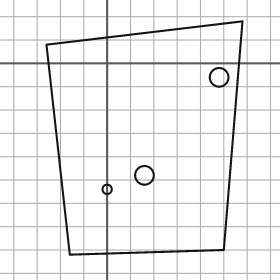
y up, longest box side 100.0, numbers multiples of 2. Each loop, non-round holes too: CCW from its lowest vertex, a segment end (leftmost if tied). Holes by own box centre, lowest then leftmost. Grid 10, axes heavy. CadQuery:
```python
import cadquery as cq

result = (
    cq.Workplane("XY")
    .moveTo(-16.0, -82.0)
    .lineTo(50.0, -80.0)
    .lineTo(58.0, 18.0)
    .lineTo(-26.0, 8.0)
    .close()
    .moveTo(0.0, -54.0)
    .circle(2.0)
    .moveTo(16.0, -48.0)
    .circle(4.0)
    .moveTo(48.0, -6.0)
    .circle(4.0)
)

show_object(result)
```